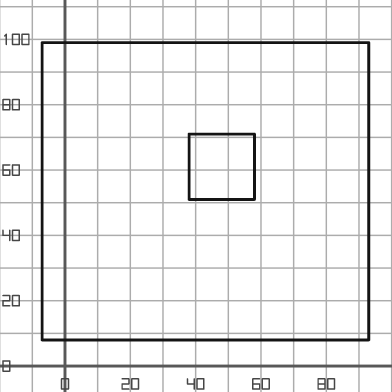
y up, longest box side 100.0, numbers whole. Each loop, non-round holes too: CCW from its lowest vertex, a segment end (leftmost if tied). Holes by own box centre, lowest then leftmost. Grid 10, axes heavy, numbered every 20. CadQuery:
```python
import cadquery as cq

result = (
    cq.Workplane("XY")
    .moveTo(-7.0, 8.0)
    .lineTo(93.0, 8.0)
    .lineTo(93.0, 99.0)
    .lineTo(-7.0, 99.0)
    .close()
    .moveTo(38.0, 51.0)
    .lineTo(58.0, 51.0)
    .lineTo(58.0, 71.0)
    .lineTo(38.0, 71.0)
    .close()
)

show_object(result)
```